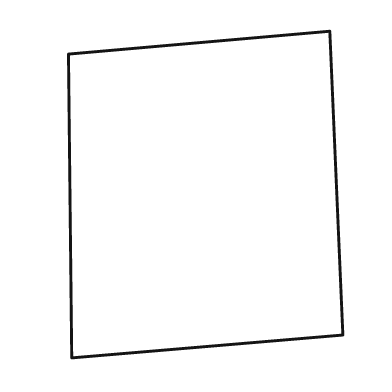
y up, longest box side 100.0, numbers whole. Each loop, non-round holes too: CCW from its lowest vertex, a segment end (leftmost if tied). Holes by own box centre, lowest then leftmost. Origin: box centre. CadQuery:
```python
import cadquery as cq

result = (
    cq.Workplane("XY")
    .moveTo(-41.0, -50.0)
    .lineTo(42.0, -43.0)
    .lineTo(38.0, 50.0)
    .lineTo(-42.0, 43.0)
    .close()
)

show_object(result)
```